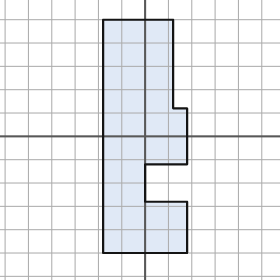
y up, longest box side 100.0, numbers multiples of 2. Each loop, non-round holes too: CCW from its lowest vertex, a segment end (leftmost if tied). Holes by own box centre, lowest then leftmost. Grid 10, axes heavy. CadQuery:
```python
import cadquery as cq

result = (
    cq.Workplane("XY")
    .moveTo(-18.0, -50.0)
    .lineTo(18.0, -50.0)
    .lineTo(18.0, -28.0)
    .lineTo(0.0, -28.0)
    .lineTo(0.0, -12.0)
    .lineTo(18.0, -12.0)
    .lineTo(18.0, 12.0)
    .lineTo(12.0, 12.0)
    .lineTo(12.0, 50.0)
    .lineTo(-18.0, 50.0)
    .close()
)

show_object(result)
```